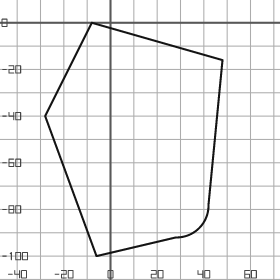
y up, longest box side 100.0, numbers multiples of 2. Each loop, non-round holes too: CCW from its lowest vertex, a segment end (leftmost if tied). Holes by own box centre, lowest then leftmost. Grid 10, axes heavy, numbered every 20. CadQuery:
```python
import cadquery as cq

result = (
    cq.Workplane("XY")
    .moveTo(-6.0, -100.0)
    .lineTo(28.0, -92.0)
    .threePointArc((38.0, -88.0), (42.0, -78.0))
    .lineTo(48.0, -16.0)
    .lineTo(-8.0, 0.0)
    .lineTo(-28.0, -40.0)
    .close()
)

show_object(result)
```